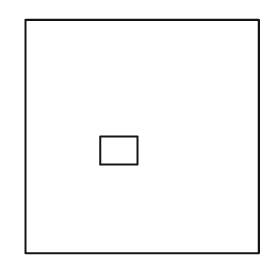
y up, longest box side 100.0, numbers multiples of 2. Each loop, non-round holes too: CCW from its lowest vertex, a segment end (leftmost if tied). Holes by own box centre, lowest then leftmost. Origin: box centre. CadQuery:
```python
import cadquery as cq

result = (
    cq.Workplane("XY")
    .moveTo(-50.0, -50.0)
    .lineTo(50.0, -50.0)
    .lineTo(50.0, 50.0)
    .lineTo(-50.0, 50.0)
    .close()
    .moveTo(-18.0, -12.0)
    .lineTo(-2.0, -12.0)
    .lineTo(-2.0, 0.0)
    .lineTo(-18.0, 0.0)
    .close()
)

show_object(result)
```